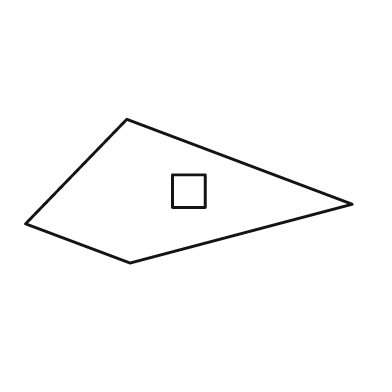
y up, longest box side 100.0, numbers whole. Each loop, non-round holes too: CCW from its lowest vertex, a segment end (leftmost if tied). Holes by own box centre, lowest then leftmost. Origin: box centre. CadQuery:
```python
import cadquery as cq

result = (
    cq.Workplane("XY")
    .moveTo(-18.0, -22.0)
    .lineTo(50.0, -4.0)
    .lineTo(-19.0, 22.0)
    .lineTo(-50.0, -10.0)
    .close()
    .moveTo(-5.0, -5.0)
    .lineTo(5.0, -5.0)
    .lineTo(5.0, 5.0)
    .lineTo(-5.0, 5.0)
    .close()
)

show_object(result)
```